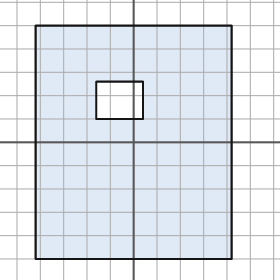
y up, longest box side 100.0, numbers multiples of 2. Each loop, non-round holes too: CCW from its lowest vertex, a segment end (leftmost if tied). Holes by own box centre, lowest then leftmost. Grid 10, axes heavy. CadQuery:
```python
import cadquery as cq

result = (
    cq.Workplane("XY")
    .moveTo(-42.0, -50.0)
    .lineTo(42.0, -50.0)
    .lineTo(42.0, 50.0)
    .lineTo(-42.0, 50.0)
    .close()
    .moveTo(-16.0, 10.0)
    .lineTo(4.0, 10.0)
    .lineTo(4.0, 26.0)
    .lineTo(-16.0, 26.0)
    .close()
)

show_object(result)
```